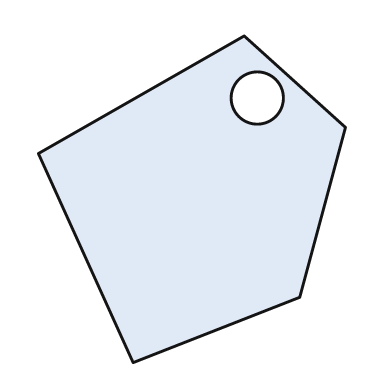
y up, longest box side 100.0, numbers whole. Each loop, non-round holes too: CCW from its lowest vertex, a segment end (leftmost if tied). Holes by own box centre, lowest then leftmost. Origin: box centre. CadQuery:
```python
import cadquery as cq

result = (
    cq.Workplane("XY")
    .moveTo(-18.0, -50.0)
    .lineTo(33.0, -30.0)
    .lineTo(47.0, 22.0)
    .lineTo(16.0, 50.0)
    .lineTo(-47.0, 14.0)
    .close()
    .moveTo(20.0, 31.0)
    .circle(8.0)
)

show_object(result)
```